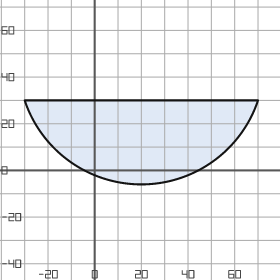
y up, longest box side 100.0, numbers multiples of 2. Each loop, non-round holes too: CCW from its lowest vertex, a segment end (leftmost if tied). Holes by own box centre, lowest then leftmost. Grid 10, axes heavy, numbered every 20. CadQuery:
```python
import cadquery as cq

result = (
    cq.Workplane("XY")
    .moveTo(-30.0, 30.0)
    .threePointArc((20.0, -6.0), (70.0, 30.0))
    .close()
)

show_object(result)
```